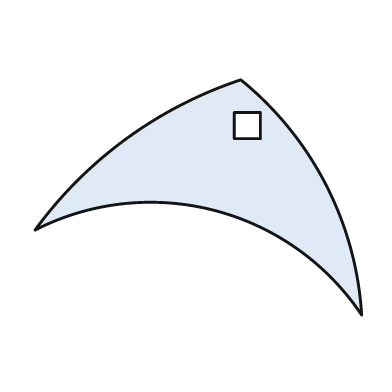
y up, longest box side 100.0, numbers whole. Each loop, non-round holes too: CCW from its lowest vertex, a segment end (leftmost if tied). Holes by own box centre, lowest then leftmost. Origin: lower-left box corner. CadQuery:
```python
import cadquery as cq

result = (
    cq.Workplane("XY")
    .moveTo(100.0, 0.0)
    .threePointArc((89.0, 40.0), (63.0, 72.0))
    .threePointArc((28.0, 54.0), (0.0, 26.0))
    .threePointArc((55.0, 32.0), (100.0, 0.0))
    .close()
    .moveTo(61.0, 54.0)
    .lineTo(69.0, 54.0)
    .lineTo(69.0, 62.0)
    .lineTo(61.0, 62.0)
    .close()
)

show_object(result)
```